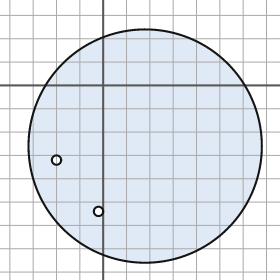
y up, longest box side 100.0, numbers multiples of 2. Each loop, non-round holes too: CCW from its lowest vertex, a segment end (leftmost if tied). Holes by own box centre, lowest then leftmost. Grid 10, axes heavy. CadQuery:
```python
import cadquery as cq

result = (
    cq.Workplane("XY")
    .moveTo(18.0, -26.0)
    .circle(50.0)
    .moveTo(-2.0, -54.0)
    .circle(2.0)
    .moveTo(-20.0, -32.0)
    .circle(2.0)
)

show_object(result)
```